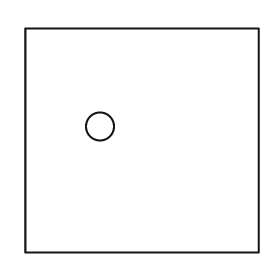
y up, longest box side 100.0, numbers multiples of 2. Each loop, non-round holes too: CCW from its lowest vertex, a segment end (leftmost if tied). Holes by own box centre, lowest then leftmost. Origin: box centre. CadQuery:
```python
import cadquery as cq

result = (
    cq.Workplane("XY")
    .moveTo(-50.0, -48.0)
    .lineTo(50.0, -48.0)
    .lineTo(50.0, 48.0)
    .lineTo(-50.0, 48.0)
    .close()
    .moveTo(-18.0, 6.0)
    .circle(6.0)
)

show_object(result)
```